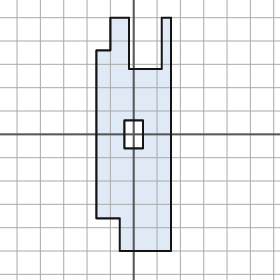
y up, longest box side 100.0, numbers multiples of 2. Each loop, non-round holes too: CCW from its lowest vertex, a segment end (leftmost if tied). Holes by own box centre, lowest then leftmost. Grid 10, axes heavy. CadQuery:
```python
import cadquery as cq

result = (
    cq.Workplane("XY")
    .moveTo(-6.0, -50.0)
    .lineTo(16.0, -50.0)
    .lineTo(16.0, 50.0)
    .lineTo(12.0, 50.0)
    .lineTo(12.0, 28.0)
    .lineTo(-2.0, 28.0)
    .lineTo(-2.0, 50.0)
    .lineTo(-10.0, 50.0)
    .lineTo(-10.0, 36.0)
    .lineTo(-16.0, 36.0)
    .lineTo(-16.0, -36.0)
    .lineTo(-6.0, -36.0)
    .close()
    .moveTo(-4.0, -6.0)
    .lineTo(4.0, -6.0)
    .lineTo(4.0, 6.0)
    .lineTo(-4.0, 6.0)
    .close()
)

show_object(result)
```